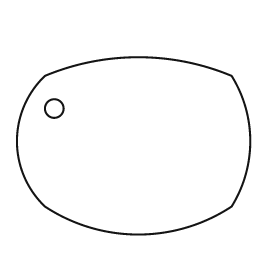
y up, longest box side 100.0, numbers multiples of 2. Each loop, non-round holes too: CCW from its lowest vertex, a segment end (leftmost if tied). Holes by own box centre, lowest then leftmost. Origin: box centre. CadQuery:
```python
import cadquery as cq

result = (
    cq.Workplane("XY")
    .moveTo(-38.0, -26.0)
    .threePointArc((2.0, -38.0), (42.0, -26.0))
    .threePointArc((50.0, 2.0), (42.0, 30.0))
    .threePointArc((2.0, 38.0), (-38.0, 30.0))
    .threePointArc((-50.0, 2.0), (-38.0, -26.0))
    .close()
    .moveTo(-34.0, 16.0)
    .circle(4.0)
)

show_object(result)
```